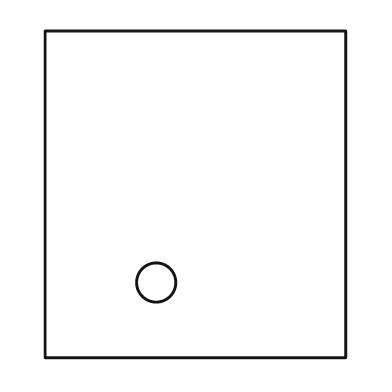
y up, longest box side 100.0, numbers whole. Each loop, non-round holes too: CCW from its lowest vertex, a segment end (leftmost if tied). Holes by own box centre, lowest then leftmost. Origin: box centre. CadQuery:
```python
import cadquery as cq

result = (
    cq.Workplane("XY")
    .moveTo(-46.0, -50.0)
    .lineTo(46.0, -50.0)
    .lineTo(46.0, 50.0)
    .lineTo(-46.0, 50.0)
    .close()
    .moveTo(-12.0, -27.0)
    .circle(6.0)
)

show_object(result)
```